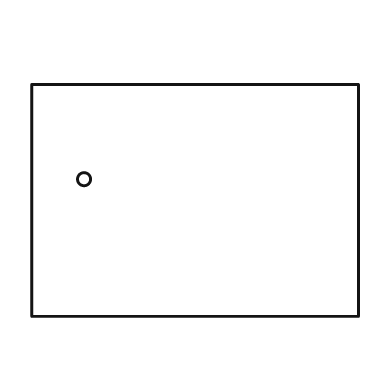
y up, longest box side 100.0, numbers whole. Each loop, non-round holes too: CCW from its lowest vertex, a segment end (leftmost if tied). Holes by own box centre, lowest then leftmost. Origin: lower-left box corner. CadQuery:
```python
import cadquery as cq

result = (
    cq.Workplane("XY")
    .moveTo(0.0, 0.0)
    .lineTo(100.0, 0.0)
    .lineTo(100.0, 71.0)
    .lineTo(0.0, 71.0)
    .close()
    .moveTo(16.0, 42.0)
    .circle(2.0)
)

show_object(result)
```